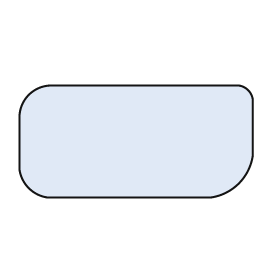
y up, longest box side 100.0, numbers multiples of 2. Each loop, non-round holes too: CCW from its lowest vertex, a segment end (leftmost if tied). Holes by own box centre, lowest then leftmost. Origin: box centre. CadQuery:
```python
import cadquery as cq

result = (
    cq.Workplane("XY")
    .moveTo(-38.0, -24.0)
    .lineTo(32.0, -24.0)
    .threePointArc((44.0, -18.0), (50.0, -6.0))
    .lineTo(50.0, 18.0)
    .threePointArc((48.0, 22.0), (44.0, 24.0))
    .lineTo(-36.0, 24.0)
    .threePointArc((-46.0, 20.0), (-50.0, 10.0))
    .lineTo(-50.0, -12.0)
    .threePointArc((-46.0, -20.0), (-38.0, -24.0))
    .close()
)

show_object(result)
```